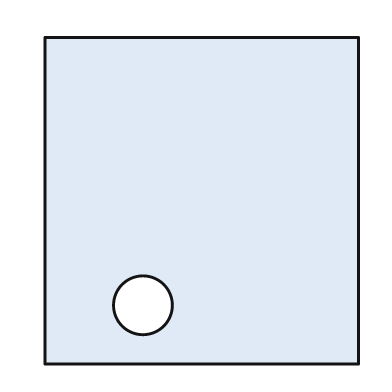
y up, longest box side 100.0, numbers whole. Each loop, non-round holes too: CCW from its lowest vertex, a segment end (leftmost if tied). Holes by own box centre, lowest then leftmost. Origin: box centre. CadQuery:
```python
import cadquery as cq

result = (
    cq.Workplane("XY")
    .moveTo(-48.0, -50.0)
    .lineTo(48.0, -50.0)
    .lineTo(48.0, 50.0)
    .lineTo(-48.0, 50.0)
    .close()
    .moveTo(-18.0, -32.0)
    .circle(9.0)
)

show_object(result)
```